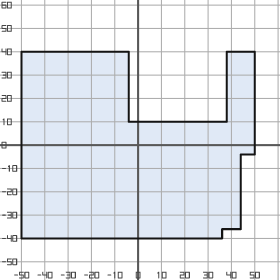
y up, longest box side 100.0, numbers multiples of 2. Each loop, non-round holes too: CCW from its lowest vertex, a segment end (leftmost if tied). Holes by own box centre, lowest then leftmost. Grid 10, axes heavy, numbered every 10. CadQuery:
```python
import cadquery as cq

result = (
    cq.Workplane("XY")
    .moveTo(-50.0, -40.0)
    .lineTo(36.0, -40.0)
    .lineTo(36.0, -36.0)
    .lineTo(44.0, -36.0)
    .lineTo(44.0, -4.0)
    .lineTo(50.0, -4.0)
    .lineTo(50.0, 40.0)
    .lineTo(38.0, 40.0)
    .lineTo(38.0, 10.0)
    .lineTo(-4.0, 10.0)
    .lineTo(-4.0, 40.0)
    .lineTo(-50.0, 40.0)
    .close()
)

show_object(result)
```